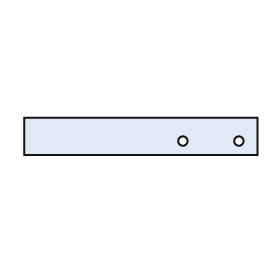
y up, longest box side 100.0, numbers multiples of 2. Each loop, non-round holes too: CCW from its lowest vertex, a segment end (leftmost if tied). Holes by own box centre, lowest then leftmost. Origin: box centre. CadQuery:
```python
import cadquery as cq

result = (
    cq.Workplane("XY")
    .moveTo(-50.0, -8.0)
    .lineTo(50.0, -8.0)
    .lineTo(50.0, 8.0)
    .lineTo(-50.0, 8.0)
    .close()
    .moveTo(18.0, -2.0)
    .circle(2.0)
    .moveTo(42.0, -2.0)
    .circle(2.0)
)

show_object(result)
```